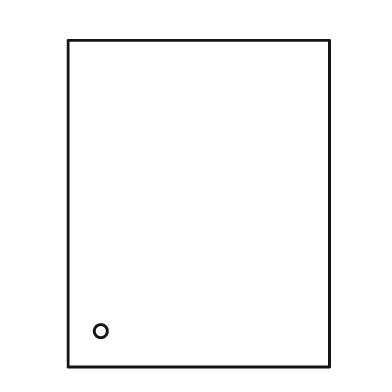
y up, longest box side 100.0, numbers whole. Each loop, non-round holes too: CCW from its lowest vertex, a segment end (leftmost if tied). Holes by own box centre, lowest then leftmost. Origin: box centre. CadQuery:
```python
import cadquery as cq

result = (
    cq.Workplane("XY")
    .moveTo(-40.0, -50.0)
    .lineTo(40.0, -50.0)
    .lineTo(40.0, 50.0)
    .lineTo(-40.0, 50.0)
    .close()
    .moveTo(-30.0, -39.0)
    .circle(2.0)
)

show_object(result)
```